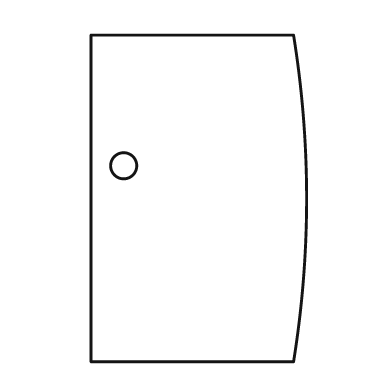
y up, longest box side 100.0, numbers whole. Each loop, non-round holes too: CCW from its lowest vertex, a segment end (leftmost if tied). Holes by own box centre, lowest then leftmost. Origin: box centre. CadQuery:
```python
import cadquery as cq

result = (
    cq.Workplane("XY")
    .moveTo(-33.0, -50.0)
    .lineTo(29.0, -50.0)
    .threePointArc((33.0, 0.0), (29.0, 50.0))
    .lineTo(-33.0, 50.0)
    .close()
    .moveTo(-23.0, 10.0)
    .circle(4.0)
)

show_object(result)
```